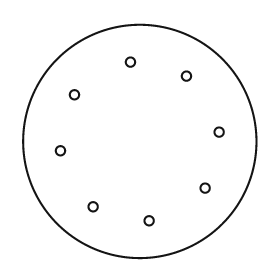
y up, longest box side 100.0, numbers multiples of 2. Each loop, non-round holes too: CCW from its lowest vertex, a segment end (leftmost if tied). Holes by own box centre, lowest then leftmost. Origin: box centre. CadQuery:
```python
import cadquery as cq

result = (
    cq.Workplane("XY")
    .moveTo(0.0, 0.0)
    .circle(50.0)
    .moveTo(4.0, -34.0)
    .circle(2.0)
    .moveTo(-20.0, -28.0)
    .circle(2.0)
    .moveTo(28.0, -20.0)
    .circle(2.0)
    .moveTo(-34.0, -4.0)
    .circle(2.0)
    .moveTo(34.0, 4.0)
    .circle(2.0)
    .moveTo(-28.0, 20.0)
    .circle(2.0)
    .moveTo(20.0, 28.0)
    .circle(2.0)
    .moveTo(-4.0, 34.0)
    .circle(2.0)
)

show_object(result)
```